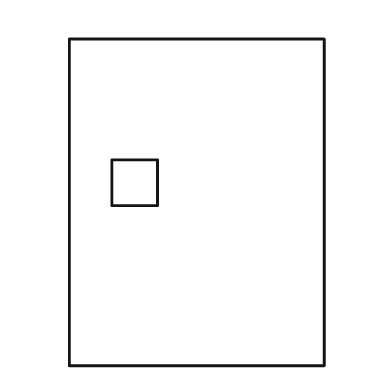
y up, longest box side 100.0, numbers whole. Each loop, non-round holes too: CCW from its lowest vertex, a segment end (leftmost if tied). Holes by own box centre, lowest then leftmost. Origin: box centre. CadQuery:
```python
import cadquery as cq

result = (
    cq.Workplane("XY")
    .moveTo(-39.0, -50.0)
    .lineTo(39.0, -50.0)
    .lineTo(39.0, 50.0)
    .lineTo(-39.0, 50.0)
    .close()
    .moveTo(-26.0, -1.0)
    .lineTo(-12.0, -1.0)
    .lineTo(-12.0, 13.0)
    .lineTo(-26.0, 13.0)
    .close()
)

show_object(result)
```